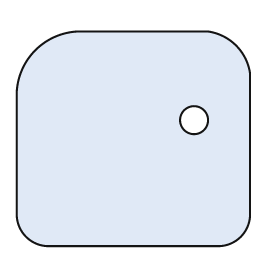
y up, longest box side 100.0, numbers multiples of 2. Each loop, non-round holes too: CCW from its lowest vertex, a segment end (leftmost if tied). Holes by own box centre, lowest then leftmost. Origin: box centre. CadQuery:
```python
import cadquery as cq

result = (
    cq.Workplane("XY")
    .moveTo(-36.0, -46.0)
    .lineTo(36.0, -46.0)
    .threePointArc((46.0, -42.0), (50.0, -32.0))
    .lineTo(50.0, 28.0)
    .threePointArc((44.0, 40.0), (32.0, 46.0))
    .lineTo(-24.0, 46.0)
    .threePointArc((-42.0, 38.0), (-50.0, 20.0))
    .lineTo(-50.0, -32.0)
    .threePointArc((-46.0, -42.0), (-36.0, -46.0))
    .close()
    .moveTo(26.0, 8.0)
    .circle(6.0)
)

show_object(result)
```